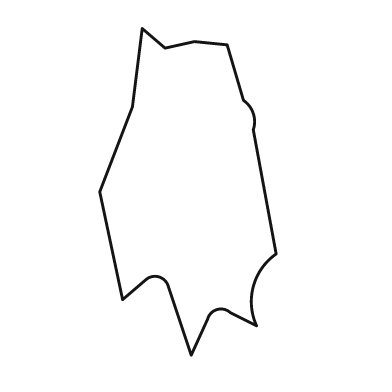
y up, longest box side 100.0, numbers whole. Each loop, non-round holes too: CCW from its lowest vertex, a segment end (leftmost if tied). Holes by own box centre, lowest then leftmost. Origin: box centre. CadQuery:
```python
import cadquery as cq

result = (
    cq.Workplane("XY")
    .moveTo(1.0, -50.0)
    .lineTo(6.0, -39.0)
    .threePointArc((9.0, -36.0), (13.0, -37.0))
    .lineTo(21.0, -41.0)
    .threePointArc((20.0, -29.0), (27.0, -19.0))
    .lineTo(20.0, 19.0)
    .threePointArc((20.0, 24.0), (17.0, 28.0))
    .lineTo(12.0, 45.0)
    .lineTo(2.0, 46.0)
    .lineTo(-7.0, 44.0)
    .lineTo(-14.0, 50.0)
    .lineTo(-17.0, 26.0)
    .lineTo(-27.0, 0.0)
    .lineTo(-20.0, -33.0)
    .lineTo(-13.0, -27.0)
    .threePointArc((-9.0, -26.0), (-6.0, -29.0))
    .close()
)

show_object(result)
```